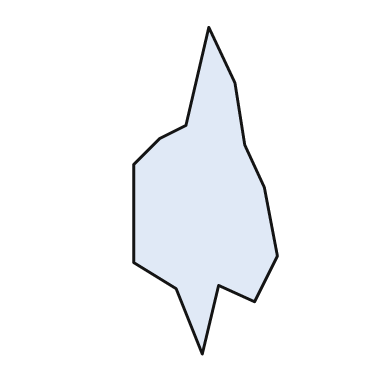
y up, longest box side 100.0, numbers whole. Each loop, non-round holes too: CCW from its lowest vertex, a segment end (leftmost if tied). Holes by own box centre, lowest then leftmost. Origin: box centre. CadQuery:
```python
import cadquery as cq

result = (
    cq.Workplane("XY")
    .moveTo(-1.0, -50.0)
    .lineTo(4.0, -29.0)
    .lineTo(15.0, -34.0)
    .lineTo(22.0, -20.0)
    .lineTo(18.0, 1.0)
    .lineTo(12.0, 14.0)
    .lineTo(9.0, 33.0)
    .lineTo(1.0, 50.0)
    .lineTo(-6.0, 20.0)
    .lineTo(-14.0, 16.0)
    .lineTo(-22.0, 8.0)
    .lineTo(-22.0, -22.0)
    .lineTo(-9.0, -30.0)
    .close()
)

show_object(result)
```